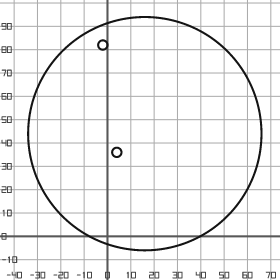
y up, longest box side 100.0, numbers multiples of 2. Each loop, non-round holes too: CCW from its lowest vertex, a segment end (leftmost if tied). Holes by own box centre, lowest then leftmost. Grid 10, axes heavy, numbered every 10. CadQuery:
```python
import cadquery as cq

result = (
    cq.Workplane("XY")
    .moveTo(16.0, 44.0)
    .circle(50.0)
    .moveTo(4.0, 36.0)
    .circle(2.0)
    .moveTo(-2.0, 82.0)
    .circle(2.0)
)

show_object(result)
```